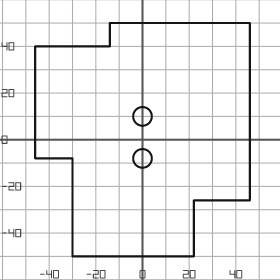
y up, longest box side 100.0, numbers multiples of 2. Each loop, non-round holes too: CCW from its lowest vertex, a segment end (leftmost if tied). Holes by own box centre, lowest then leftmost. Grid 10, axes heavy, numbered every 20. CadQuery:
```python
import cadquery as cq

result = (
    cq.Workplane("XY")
    .moveTo(-30.0, -50.0)
    .lineTo(22.0, -50.0)
    .lineTo(22.0, -26.0)
    .lineTo(46.0, -26.0)
    .lineTo(46.0, 50.0)
    .lineTo(-14.0, 50.0)
    .lineTo(-14.0, 40.0)
    .lineTo(-46.0, 40.0)
    .lineTo(-46.0, -8.0)
    .lineTo(-30.0, -8.0)
    .close()
    .moveTo(0.0, -8.0)
    .circle(4.0)
    .moveTo(0.0, 10.0)
    .circle(4.0)
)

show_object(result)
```